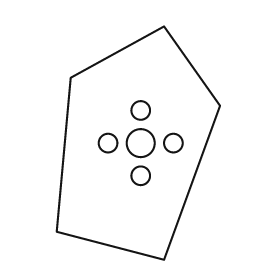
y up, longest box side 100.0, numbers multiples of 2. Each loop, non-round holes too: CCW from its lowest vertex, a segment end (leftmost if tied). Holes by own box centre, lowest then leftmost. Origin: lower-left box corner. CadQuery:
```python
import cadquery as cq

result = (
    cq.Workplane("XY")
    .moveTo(46.0, 0.0)
    .lineTo(70.0, 66.0)
    .lineTo(46.0, 100.0)
    .lineTo(6.0, 78.0)
    .lineTo(0.0, 12.0)
    .close()
    .moveTo(36.0, 36.0)
    .circle(4.0)
    .moveTo(22.0, 50.0)
    .circle(4.0)
    .moveTo(36.0, 50.0)
    .circle(6.0)
    .moveTo(50.0, 50.0)
    .circle(4.0)
    .moveTo(36.0, 64.0)
    .circle(4.0)
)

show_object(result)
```